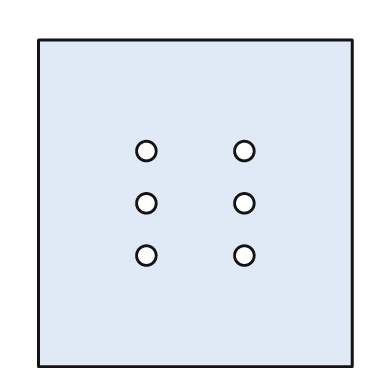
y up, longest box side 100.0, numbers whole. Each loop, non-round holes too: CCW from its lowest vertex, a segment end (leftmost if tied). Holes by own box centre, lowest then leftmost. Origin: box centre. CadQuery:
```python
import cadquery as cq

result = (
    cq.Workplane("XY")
    .moveTo(-48.0, -50.0)
    .lineTo(48.0, -50.0)
    .lineTo(48.0, 50.0)
    .lineTo(-48.0, 50.0)
    .close()
    .moveTo(-15.0, -16.0)
    .circle(3.0)
    .moveTo(15.0, -16.0)
    .circle(3.0)
    .moveTo(-15.0, 0.0)
    .circle(3.0)
    .moveTo(15.0, 0.0)
    .circle(3.0)
    .moveTo(-15.0, 16.0)
    .circle(3.0)
    .moveTo(15.0, 16.0)
    .circle(3.0)
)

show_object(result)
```